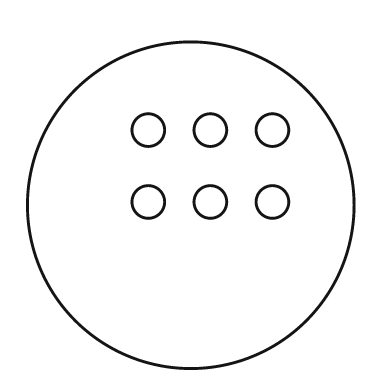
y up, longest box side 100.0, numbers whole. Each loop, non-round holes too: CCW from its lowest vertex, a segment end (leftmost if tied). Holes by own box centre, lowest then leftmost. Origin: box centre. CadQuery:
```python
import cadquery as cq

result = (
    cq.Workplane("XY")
    .moveTo(0.0, 0.0)
    .circle(50.0)
    .moveTo(-13.0, 1.0)
    .circle(5.0)
    .moveTo(6.0, 1.0)
    .circle(5.0)
    .moveTo(25.0, 1.0)
    .circle(5.0)
    .moveTo(-13.0, 23.0)
    .circle(5.0)
    .moveTo(6.0, 23.0)
    .circle(5.0)
    .moveTo(25.0, 23.0)
    .circle(5.0)
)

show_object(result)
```